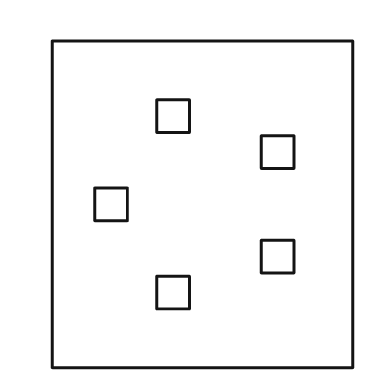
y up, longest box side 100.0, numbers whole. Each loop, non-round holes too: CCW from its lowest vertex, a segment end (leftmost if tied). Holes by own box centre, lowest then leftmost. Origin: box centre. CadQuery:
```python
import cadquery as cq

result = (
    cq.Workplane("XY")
    .moveTo(-46.0, -50.0)
    .lineTo(46.0, -50.0)
    .lineTo(46.0, 50.0)
    .lineTo(-46.0, 50.0)
    .close()
    .moveTo(-14.0, -32.0)
    .lineTo(-4.0, -32.0)
    .lineTo(-4.0, -22.0)
    .lineTo(-14.0, -22.0)
    .close()
    .moveTo(18.0, -21.0)
    .lineTo(28.0, -21.0)
    .lineTo(28.0, -11.0)
    .lineTo(18.0, -11.0)
    .close()
    .moveTo(-33.0, -5.0)
    .lineTo(-23.0, -5.0)
    .lineTo(-23.0, 5.0)
    .lineTo(-33.0, 5.0)
    .close()
    .moveTo(18.0, 11.0)
    .lineTo(28.0, 11.0)
    .lineTo(28.0, 21.0)
    .lineTo(18.0, 21.0)
    .close()
    .moveTo(-14.0, 22.0)
    .lineTo(-4.0, 22.0)
    .lineTo(-4.0, 32.0)
    .lineTo(-14.0, 32.0)
    .close()
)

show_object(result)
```